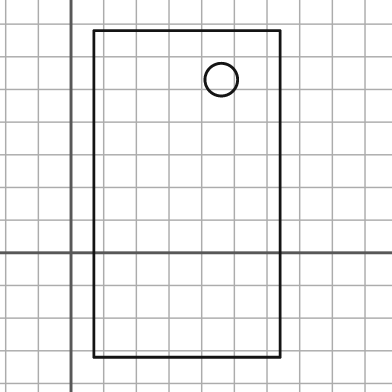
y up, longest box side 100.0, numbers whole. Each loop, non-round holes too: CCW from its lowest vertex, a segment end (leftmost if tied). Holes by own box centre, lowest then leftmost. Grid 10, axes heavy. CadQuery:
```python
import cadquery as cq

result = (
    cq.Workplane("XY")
    .moveTo(7.0, -32.0)
    .lineTo(64.0, -32.0)
    .lineTo(64.0, 68.0)
    .lineTo(7.0, 68.0)
    .close()
    .moveTo(46.0, 53.0)
    .circle(5.0)
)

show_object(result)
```